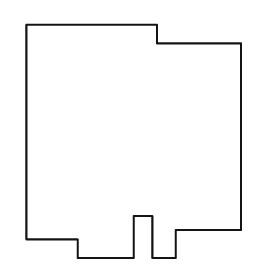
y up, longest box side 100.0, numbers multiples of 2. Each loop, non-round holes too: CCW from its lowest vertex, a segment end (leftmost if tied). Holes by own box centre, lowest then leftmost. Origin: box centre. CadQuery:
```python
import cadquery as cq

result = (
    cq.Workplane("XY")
    .moveTo(-24.0, -50.0)
    .lineTo(0.0, -50.0)
    .lineTo(0.0, -32.0)
    .lineTo(8.0, -32.0)
    .lineTo(8.0, -50.0)
    .lineTo(18.0, -50.0)
    .lineTo(18.0, -38.0)
    .lineTo(46.0, -38.0)
    .lineTo(46.0, 42.0)
    .lineTo(10.0, 42.0)
    .lineTo(10.0, 50.0)
    .lineTo(-46.0, 50.0)
    .lineTo(-46.0, -42.0)
    .lineTo(-24.0, -42.0)
    .close()
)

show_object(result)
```